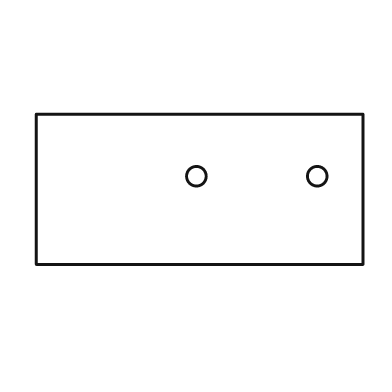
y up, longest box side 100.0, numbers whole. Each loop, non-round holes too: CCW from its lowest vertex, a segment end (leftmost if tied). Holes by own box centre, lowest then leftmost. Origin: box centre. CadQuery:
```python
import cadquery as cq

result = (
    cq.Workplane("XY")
    .moveTo(-50.0, -23.0)
    .lineTo(50.0, -23.0)
    .lineTo(50.0, 23.0)
    .lineTo(-50.0, 23.0)
    .close()
    .moveTo(-1.0, 4.0)
    .circle(3.0)
    .moveTo(36.0, 4.0)
    .circle(3.0)
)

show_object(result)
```